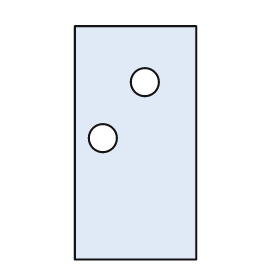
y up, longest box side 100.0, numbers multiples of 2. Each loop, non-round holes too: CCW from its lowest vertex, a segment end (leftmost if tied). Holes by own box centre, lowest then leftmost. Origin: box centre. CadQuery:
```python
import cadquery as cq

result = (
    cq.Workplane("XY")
    .moveTo(-26.0, -50.0)
    .lineTo(26.0, -50.0)
    .lineTo(26.0, 50.0)
    .lineTo(-26.0, 50.0)
    .close()
    .moveTo(-14.0, 2.0)
    .circle(6.0)
    .moveTo(4.0, 26.0)
    .circle(6.0)
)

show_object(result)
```